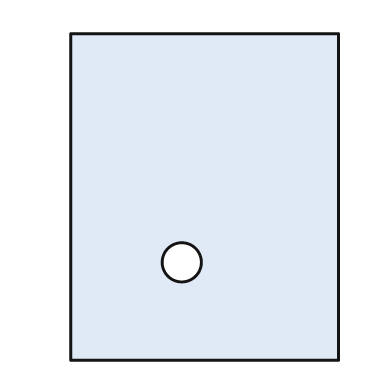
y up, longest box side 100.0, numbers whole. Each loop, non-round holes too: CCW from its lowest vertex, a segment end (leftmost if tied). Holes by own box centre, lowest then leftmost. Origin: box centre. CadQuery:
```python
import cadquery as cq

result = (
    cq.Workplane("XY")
    .moveTo(-41.0, -50.0)
    .lineTo(41.0, -50.0)
    .lineTo(41.0, 50.0)
    .lineTo(-41.0, 50.0)
    .close()
    .moveTo(-7.0, -20.0)
    .circle(6.0)
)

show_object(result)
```